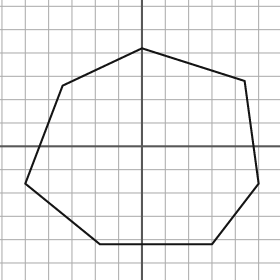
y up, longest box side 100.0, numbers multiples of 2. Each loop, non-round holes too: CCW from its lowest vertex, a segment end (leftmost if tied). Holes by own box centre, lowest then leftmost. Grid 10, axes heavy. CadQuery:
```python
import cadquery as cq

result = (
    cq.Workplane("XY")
    .moveTo(-18.0, -42.0)
    .lineTo(30.0, -42.0)
    .lineTo(50.0, -16.0)
    .lineTo(44.0, 28.0)
    .lineTo(0.0, 42.0)
    .lineTo(-34.0, 26.0)
    .lineTo(-50.0, -16.0)
    .close()
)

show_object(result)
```